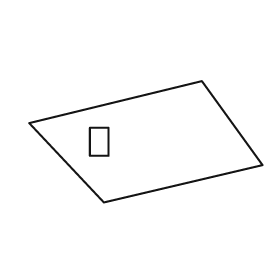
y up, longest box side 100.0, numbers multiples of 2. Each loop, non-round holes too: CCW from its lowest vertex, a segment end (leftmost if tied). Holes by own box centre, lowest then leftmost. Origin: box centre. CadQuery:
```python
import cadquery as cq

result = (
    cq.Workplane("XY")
    .moveTo(-18.0, -26.0)
    .lineTo(50.0, -10.0)
    .lineTo(24.0, 26.0)
    .lineTo(-50.0, 8.0)
    .close()
    .moveTo(-24.0, -6.0)
    .lineTo(-16.0, -6.0)
    .lineTo(-16.0, 6.0)
    .lineTo(-24.0, 6.0)
    .close()
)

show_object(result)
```